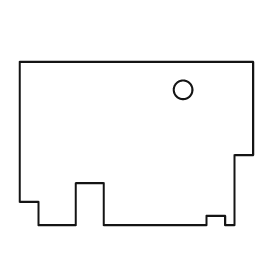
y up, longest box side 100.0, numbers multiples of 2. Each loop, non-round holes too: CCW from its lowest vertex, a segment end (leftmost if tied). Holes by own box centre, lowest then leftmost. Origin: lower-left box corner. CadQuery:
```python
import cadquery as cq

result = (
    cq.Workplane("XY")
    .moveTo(8.0, 0.0)
    .lineTo(24.0, 0.0)
    .lineTo(24.0, 18.0)
    .lineTo(36.0, 18.0)
    .lineTo(36.0, 0.0)
    .lineTo(80.0, 0.0)
    .lineTo(80.0, 4.0)
    .lineTo(88.0, 4.0)
    .lineTo(88.0, 0.0)
    .lineTo(92.0, 0.0)
    .lineTo(92.0, 30.0)
    .lineTo(100.0, 30.0)
    .lineTo(100.0, 70.0)
    .lineTo(0.0, 70.0)
    .lineTo(0.0, 10.0)
    .lineTo(8.0, 10.0)
    .close()
    .moveTo(70.0, 58.0)
    .circle(4.0)
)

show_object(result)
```